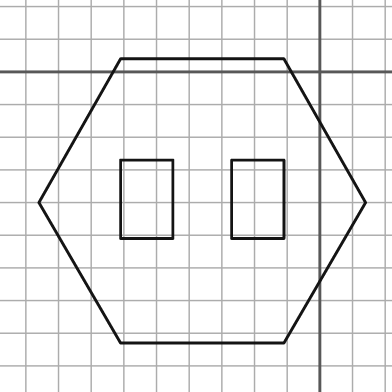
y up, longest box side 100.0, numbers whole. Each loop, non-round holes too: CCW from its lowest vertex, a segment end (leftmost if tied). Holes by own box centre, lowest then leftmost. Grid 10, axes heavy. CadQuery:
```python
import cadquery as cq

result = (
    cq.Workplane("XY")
    .moveTo(-61.0, -83.0)
    .lineTo(-11.0, -83.0)
    .lineTo(14.0, -40.0)
    .lineTo(-11.0, 4.0)
    .lineTo(-61.0, 4.0)
    .lineTo(-86.0, -40.0)
    .close()
    .moveTo(-61.0, -51.0)
    .lineTo(-45.0, -51.0)
    .lineTo(-45.0, -27.0)
    .lineTo(-61.0, -27.0)
    .close()
    .moveTo(-27.0, -51.0)
    .lineTo(-11.0, -51.0)
    .lineTo(-11.0, -27.0)
    .lineTo(-27.0, -27.0)
    .close()
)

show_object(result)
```